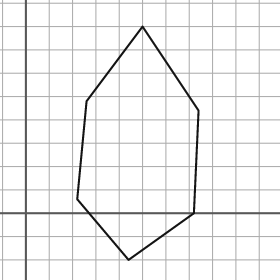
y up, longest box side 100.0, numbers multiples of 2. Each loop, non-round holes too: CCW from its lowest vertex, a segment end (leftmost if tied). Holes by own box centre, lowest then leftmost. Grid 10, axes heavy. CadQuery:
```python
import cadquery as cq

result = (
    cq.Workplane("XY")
    .moveTo(44.0, -20.0)
    .lineTo(72.0, 0.0)
    .lineTo(74.0, 44.0)
    .lineTo(50.0, 80.0)
    .lineTo(26.0, 48.0)
    .lineTo(22.0, 6.0)
    .close()
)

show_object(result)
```